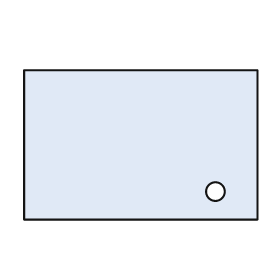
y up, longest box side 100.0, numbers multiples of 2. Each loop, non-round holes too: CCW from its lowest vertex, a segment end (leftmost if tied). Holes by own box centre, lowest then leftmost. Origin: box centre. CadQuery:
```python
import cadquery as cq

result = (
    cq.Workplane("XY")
    .moveTo(-50.0, -32.0)
    .lineTo(50.0, -32.0)
    .lineTo(50.0, 32.0)
    .lineTo(-50.0, 32.0)
    .close()
    .moveTo(32.0, -20.0)
    .circle(4.0)
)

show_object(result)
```